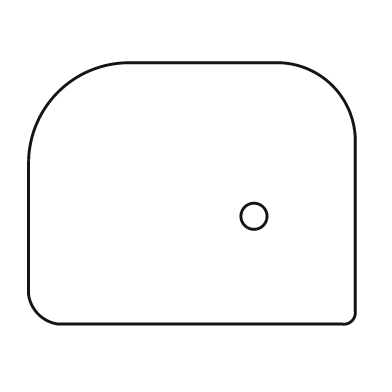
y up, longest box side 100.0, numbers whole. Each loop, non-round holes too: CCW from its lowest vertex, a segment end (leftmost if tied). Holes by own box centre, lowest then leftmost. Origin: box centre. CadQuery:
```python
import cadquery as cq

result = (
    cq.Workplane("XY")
    .moveTo(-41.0, -40.0)
    .lineTo(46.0, -40.0)
    .threePointArc((49.0, -39.0), (50.0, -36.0))
    .lineTo(50.0, 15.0)
    .threePointArc((43.0, 33.0), (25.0, 40.0))
    .lineTo(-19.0, 40.0)
    .threePointArc((-41.0, 31.0), (-50.0, 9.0))
    .lineTo(-50.0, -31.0)
    .threePointArc((-47.0, -37.0), (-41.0, -40.0))
    .close()
    .moveTo(19.0, -7.0)
    .circle(4.0)
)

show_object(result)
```